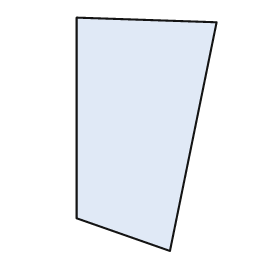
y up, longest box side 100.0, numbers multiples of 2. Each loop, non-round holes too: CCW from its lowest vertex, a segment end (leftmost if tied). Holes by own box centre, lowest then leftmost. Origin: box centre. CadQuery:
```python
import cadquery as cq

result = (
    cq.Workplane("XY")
    .moveTo(10.0, -50.0)
    .lineTo(30.0, 48.0)
    .lineTo(-30.0, 50.0)
    .lineTo(-30.0, -36.0)
    .close()
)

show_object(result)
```